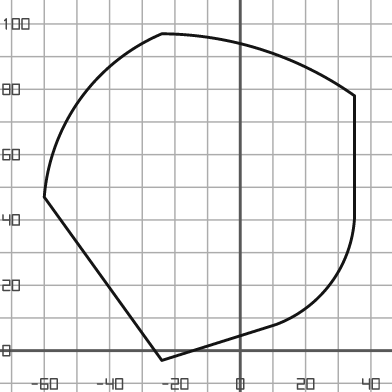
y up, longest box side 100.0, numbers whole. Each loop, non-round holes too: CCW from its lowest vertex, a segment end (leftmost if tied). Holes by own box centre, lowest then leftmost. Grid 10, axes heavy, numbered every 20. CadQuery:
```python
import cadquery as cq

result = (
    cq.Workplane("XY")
    .moveTo(-24.0, -3.0)
    .lineTo(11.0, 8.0)
    .threePointArc((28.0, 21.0), (35.0, 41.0))
    .lineTo(35.0, 78.0)
    .threePointArc((7.0, 92.0), (-24.0, 97.0))
    .threePointArc((-49.0, 77.0), (-60.0, 47.0))
    .close()
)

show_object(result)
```